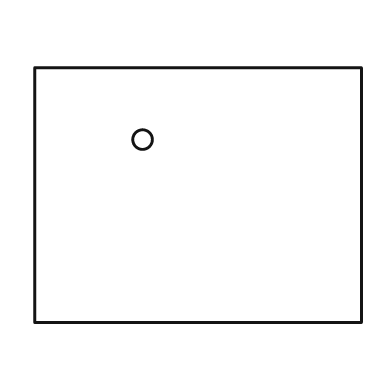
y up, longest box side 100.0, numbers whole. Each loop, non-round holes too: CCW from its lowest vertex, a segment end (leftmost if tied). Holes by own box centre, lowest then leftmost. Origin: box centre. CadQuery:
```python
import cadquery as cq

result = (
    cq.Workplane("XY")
    .moveTo(-50.0, -39.0)
    .lineTo(50.0, -39.0)
    .lineTo(50.0, 39.0)
    .lineTo(-50.0, 39.0)
    .close()
    .moveTo(-17.0, 17.0)
    .circle(3.0)
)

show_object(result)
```